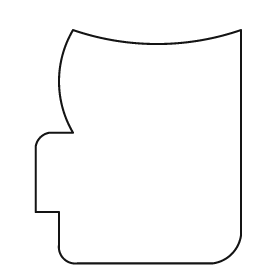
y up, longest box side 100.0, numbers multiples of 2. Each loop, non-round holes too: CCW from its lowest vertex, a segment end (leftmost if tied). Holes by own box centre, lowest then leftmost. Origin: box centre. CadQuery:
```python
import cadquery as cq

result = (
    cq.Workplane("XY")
    .moveTo(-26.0, -50.0)
    .lineTo(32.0, -50.0)
    .threePointArc((40.0, -46.0), (44.0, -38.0))
    .lineTo(44.0, 50.0)
    .threePointArc((8.0, 44.0), (-28.0, 50.0))
    .threePointArc((-34.0, 28.0), (-28.0, 6.0))
    .lineTo(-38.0, 6.0)
    .threePointArc((-42.0, 4.0), (-44.0, 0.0))
    .lineTo(-44.0, -28.0)
    .lineTo(-34.0, -28.0)
    .lineTo(-34.0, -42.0)
    .threePointArc((-32.0, -48.0), (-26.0, -50.0))
    .close()
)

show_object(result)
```